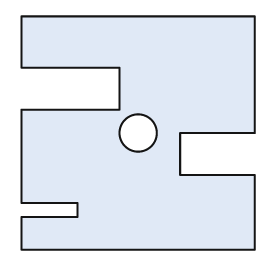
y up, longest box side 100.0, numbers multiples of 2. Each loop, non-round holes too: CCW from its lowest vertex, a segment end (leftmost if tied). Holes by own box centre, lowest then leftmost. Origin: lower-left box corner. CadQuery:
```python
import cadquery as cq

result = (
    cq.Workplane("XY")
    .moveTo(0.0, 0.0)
    .lineTo(100.0, 0.0)
    .lineTo(100.0, 32.0)
    .lineTo(68.0, 32.0)
    .lineTo(68.0, 50.0)
    .lineTo(100.0, 50.0)
    .lineTo(100.0, 100.0)
    .lineTo(0.0, 100.0)
    .lineTo(0.0, 78.0)
    .lineTo(42.0, 78.0)
    .lineTo(42.0, 60.0)
    .lineTo(0.0, 60.0)
    .lineTo(0.0, 20.0)
    .lineTo(24.0, 20.0)
    .lineTo(24.0, 14.0)
    .lineTo(0.0, 14.0)
    .close()
    .moveTo(50.0, 50.0)
    .circle(8.0)
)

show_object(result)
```